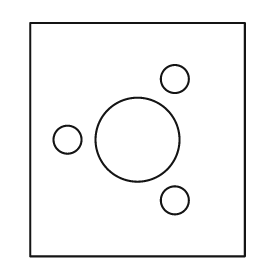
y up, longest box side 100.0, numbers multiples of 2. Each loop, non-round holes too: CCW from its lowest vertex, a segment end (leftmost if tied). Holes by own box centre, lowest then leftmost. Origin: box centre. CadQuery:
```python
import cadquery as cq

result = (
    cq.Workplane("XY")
    .moveTo(-46.0, -50.0)
    .lineTo(46.0, -50.0)
    .lineTo(46.0, 50.0)
    .lineTo(-46.0, 50.0)
    .close()
    .moveTo(16.0, -26.0)
    .circle(6.0)
    .moveTo(-30.0, 0.0)
    .circle(6.0)
    .moveTo(0.0, 0.0)
    .circle(18.0)
    .moveTo(16.0, 26.0)
    .circle(6.0)
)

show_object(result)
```